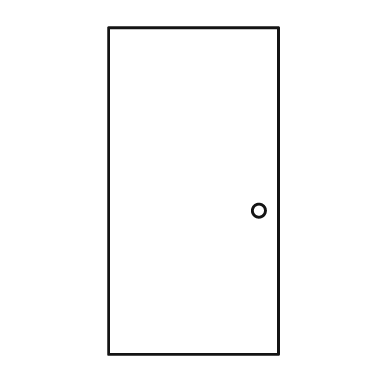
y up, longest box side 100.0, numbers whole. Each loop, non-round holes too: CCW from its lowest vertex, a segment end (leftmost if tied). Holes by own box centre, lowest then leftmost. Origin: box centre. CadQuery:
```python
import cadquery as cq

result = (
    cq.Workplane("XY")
    .moveTo(-26.0, -50.0)
    .lineTo(26.0, -50.0)
    .lineTo(26.0, 50.0)
    .lineTo(-26.0, 50.0)
    .close()
    .moveTo(20.0, -6.0)
    .circle(2.0)
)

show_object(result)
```